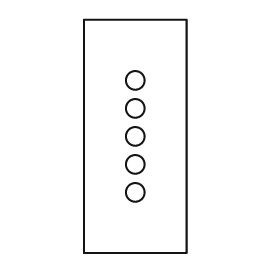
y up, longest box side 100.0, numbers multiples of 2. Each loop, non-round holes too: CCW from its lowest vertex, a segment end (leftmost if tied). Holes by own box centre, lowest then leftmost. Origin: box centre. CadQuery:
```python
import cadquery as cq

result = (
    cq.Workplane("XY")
    .moveTo(-22.0, -50.0)
    .lineTo(22.0, -50.0)
    .lineTo(22.0, 50.0)
    .lineTo(-22.0, 50.0)
    .close()
    .moveTo(0.0, -24.0)
    .circle(4.0)
    .moveTo(0.0, -12.0)
    .circle(4.0)
    .moveTo(0.0, 0.0)
    .circle(4.0)
    .moveTo(0.0, 12.0)
    .circle(4.0)
    .moveTo(0.0, 24.0)
    .circle(4.0)
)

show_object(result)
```